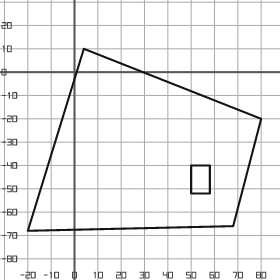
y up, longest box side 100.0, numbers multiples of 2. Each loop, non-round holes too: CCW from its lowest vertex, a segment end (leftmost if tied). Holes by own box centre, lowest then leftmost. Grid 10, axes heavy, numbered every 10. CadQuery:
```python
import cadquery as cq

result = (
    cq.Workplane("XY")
    .moveTo(-20.0, -68.0)
    .lineTo(68.0, -66.0)
    .lineTo(80.0, -20.0)
    .lineTo(4.0, 10.0)
    .close()
    .moveTo(50.0, -52.0)
    .lineTo(58.0, -52.0)
    .lineTo(58.0, -40.0)
    .lineTo(50.0, -40.0)
    .close()
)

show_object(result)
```